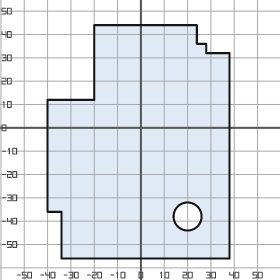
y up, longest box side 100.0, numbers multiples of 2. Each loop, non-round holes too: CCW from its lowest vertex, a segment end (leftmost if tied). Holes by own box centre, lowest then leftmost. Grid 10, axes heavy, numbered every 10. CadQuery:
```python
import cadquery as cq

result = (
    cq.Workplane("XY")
    .moveTo(-34.0, -56.0)
    .lineTo(38.0, -56.0)
    .lineTo(38.0, 32.0)
    .lineTo(28.0, 32.0)
    .lineTo(28.0, 36.0)
    .lineTo(24.0, 36.0)
    .lineTo(24.0, 44.0)
    .lineTo(-20.0, 44.0)
    .lineTo(-20.0, 12.0)
    .lineTo(-40.0, 12.0)
    .lineTo(-40.0, -36.0)
    .lineTo(-34.0, -36.0)
    .close()
    .moveTo(20.0, -38.0)
    .circle(6.0)
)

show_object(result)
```